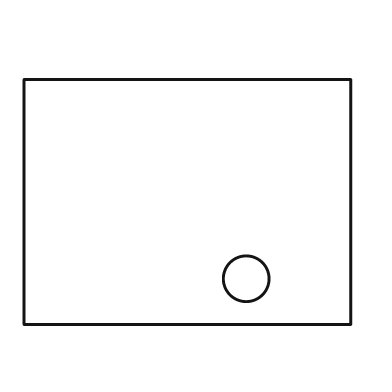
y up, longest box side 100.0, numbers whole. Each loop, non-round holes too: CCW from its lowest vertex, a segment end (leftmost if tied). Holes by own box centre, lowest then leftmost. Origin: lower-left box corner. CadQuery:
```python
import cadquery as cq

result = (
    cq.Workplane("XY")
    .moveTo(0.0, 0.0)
    .lineTo(100.0, 0.0)
    .lineTo(100.0, 75.0)
    .lineTo(0.0, 75.0)
    .close()
    .moveTo(68.0, 14.0)
    .circle(7.0)
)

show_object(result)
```